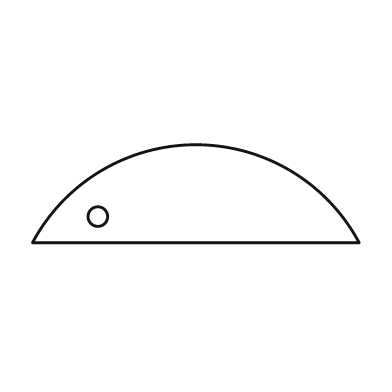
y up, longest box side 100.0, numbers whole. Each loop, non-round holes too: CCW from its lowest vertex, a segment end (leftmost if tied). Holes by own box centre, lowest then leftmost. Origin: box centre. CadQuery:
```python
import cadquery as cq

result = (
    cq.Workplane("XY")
    .moveTo(-50.0, -15.0)
    .lineTo(50.0, -15.0)
    .threePointArc((0.0, 15.0), (-50.0, -15.0))
    .close()
    .moveTo(-30.0, -7.0)
    .circle(3.0)
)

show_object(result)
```